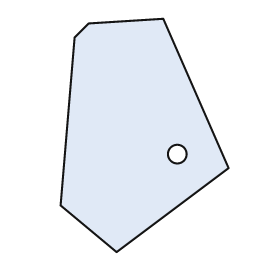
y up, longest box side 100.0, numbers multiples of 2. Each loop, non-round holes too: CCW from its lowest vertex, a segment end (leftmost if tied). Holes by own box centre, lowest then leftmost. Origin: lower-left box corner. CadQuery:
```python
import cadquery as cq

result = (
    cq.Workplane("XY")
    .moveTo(24.0, 0.0)
    .lineTo(72.0, 36.0)
    .lineTo(44.0, 100.0)
    .lineTo(12.0, 98.0)
    .lineTo(6.0, 92.0)
    .lineTo(0.0, 20.0)
    .close()
    .moveTo(50.0, 42.0)
    .circle(4.0)
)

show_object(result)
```